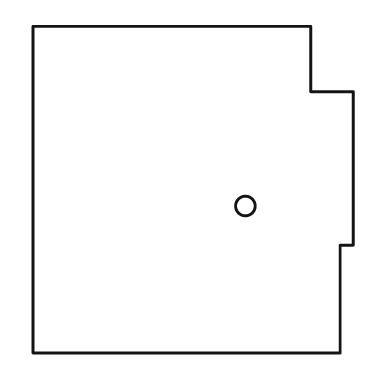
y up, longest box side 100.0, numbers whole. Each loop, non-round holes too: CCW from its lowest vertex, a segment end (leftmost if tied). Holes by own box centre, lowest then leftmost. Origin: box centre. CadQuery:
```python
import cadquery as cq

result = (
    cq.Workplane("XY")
    .moveTo(-49.0, -50.0)
    .lineTo(45.0, -50.0)
    .lineTo(45.0, -17.0)
    .lineTo(49.0, -17.0)
    .lineTo(49.0, 30.0)
    .lineTo(36.0, 30.0)
    .lineTo(36.0, 50.0)
    .lineTo(-49.0, 50.0)
    .close()
    .moveTo(16.0, -5.0)
    .circle(3.0)
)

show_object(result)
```